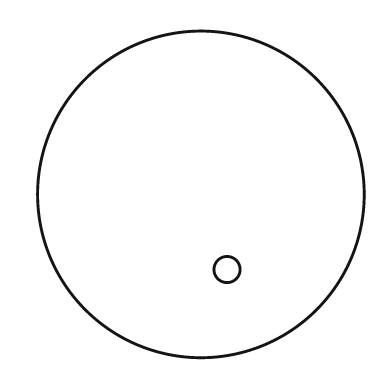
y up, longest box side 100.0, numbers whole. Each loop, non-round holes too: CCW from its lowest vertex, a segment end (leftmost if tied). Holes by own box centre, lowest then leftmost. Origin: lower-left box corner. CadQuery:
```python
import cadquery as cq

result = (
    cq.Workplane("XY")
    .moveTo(50.0, 50.0)
    .circle(50.0)
    .moveTo(58.0, 27.0)
    .circle(4.0)
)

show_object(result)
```